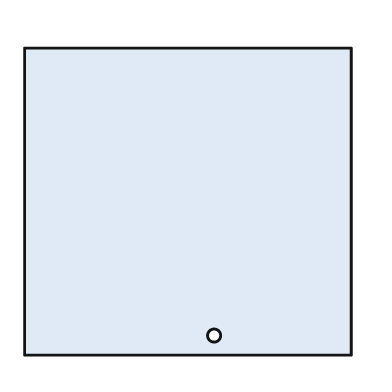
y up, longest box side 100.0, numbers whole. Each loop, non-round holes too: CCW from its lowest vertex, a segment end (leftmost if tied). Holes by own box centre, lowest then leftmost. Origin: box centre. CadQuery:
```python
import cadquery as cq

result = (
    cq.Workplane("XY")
    .moveTo(-50.0, -47.0)
    .lineTo(50.0, -47.0)
    .lineTo(50.0, 47.0)
    .lineTo(-50.0, 47.0)
    .close()
    .moveTo(8.0, -41.0)
    .circle(2.0)
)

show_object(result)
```